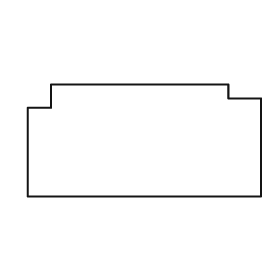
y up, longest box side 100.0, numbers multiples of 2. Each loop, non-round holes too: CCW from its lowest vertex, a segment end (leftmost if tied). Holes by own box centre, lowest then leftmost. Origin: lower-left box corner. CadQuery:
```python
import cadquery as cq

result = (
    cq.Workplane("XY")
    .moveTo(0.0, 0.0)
    .lineTo(100.0, 0.0)
    .lineTo(100.0, 42.0)
    .lineTo(86.0, 42.0)
    .lineTo(86.0, 48.0)
    .lineTo(10.0, 48.0)
    .lineTo(10.0, 38.0)
    .lineTo(0.0, 38.0)
    .close()
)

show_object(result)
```